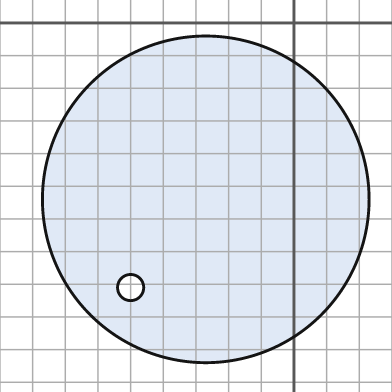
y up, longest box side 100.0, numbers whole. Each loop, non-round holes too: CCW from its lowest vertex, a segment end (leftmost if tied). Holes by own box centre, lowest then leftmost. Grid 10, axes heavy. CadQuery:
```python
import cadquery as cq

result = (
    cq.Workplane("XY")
    .moveTo(-27.0, -54.0)
    .circle(50.0)
    .moveTo(-50.0, -81.0)
    .circle(4.0)
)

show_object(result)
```